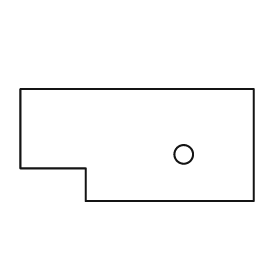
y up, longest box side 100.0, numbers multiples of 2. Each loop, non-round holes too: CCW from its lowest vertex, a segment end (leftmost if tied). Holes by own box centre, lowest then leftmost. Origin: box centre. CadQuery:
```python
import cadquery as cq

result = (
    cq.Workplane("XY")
    .moveTo(-22.0, -24.0)
    .lineTo(50.0, -24.0)
    .lineTo(50.0, 24.0)
    .lineTo(-50.0, 24.0)
    .lineTo(-50.0, -10.0)
    .lineTo(-22.0, -10.0)
    .close()
    .moveTo(20.0, -4.0)
    .circle(4.0)
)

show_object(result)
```